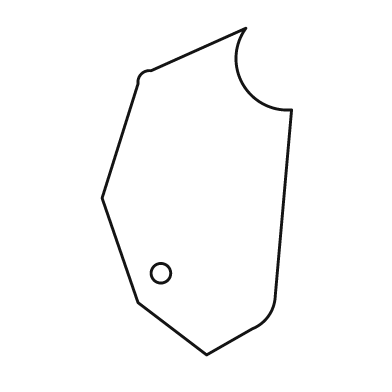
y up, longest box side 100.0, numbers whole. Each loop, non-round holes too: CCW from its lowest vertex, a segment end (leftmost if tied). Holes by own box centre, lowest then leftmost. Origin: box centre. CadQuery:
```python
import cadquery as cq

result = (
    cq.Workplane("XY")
    .moveTo(3.0, -50.0)
    .lineTo(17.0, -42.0)
    .threePointArc((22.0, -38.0), (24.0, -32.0))
    .lineTo(29.0, 25.0)
    .threePointArc((14.0, 33.0), (15.0, 50.0))
    .lineTo(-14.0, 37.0)
    .threePointArc((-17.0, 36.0), (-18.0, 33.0))
    .lineTo(-29.0, -2.0)
    .lineTo(-18.0, -34.0)
    .close()
    .moveTo(-11.0, -25.0)
    .circle(3.0)
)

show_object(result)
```